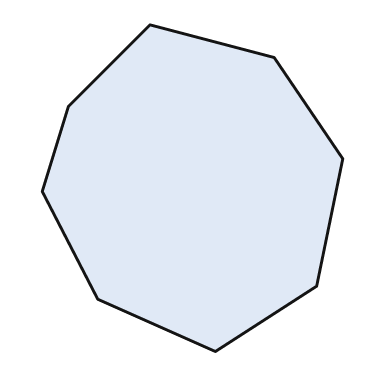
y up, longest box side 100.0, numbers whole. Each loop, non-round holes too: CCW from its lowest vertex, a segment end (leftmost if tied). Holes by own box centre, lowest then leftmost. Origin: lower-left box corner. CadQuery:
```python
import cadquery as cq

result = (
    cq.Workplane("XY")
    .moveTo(53.0, 0.0)
    .lineTo(84.0, 20.0)
    .lineTo(92.0, 59.0)
    .lineTo(71.0, 90.0)
    .lineTo(33.0, 100.0)
    .lineTo(8.0, 75.0)
    .lineTo(0.0, 49.0)
    .lineTo(17.0, 16.0)
    .close()
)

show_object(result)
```